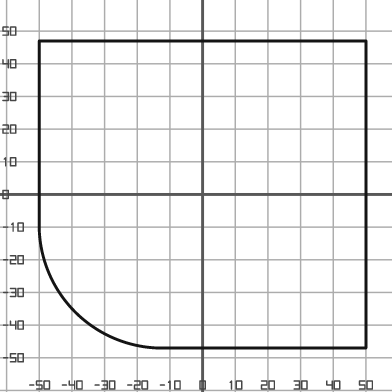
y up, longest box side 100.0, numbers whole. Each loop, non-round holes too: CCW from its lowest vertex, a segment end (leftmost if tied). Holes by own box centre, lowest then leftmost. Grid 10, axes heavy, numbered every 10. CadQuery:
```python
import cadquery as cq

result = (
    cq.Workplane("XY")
    .moveTo(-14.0, -47.0)
    .lineTo(50.0, -47.0)
    .lineTo(50.0, 47.0)
    .lineTo(-50.0, 47.0)
    .lineTo(-50.0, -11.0)
    .threePointArc((-39.0, -36.0), (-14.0, -47.0))
    .close()
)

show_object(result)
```